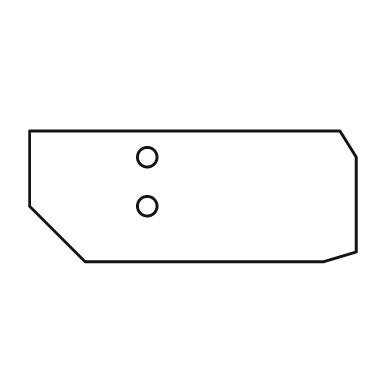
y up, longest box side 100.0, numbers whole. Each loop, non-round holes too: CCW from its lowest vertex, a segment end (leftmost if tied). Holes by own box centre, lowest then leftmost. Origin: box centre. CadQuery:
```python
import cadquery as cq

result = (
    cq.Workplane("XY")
    .moveTo(-33.0, -20.0)
    .lineTo(40.0, -20.0)
    .lineTo(50.0, -17.0)
    .lineTo(50.0, 12.0)
    .lineTo(45.0, 20.0)
    .lineTo(-50.0, 20.0)
    .lineTo(-50.0, -3.0)
    .close()
    .moveTo(-14.0, -3.0)
    .circle(3.0)
    .moveTo(-14.0, 12.0)
    .circle(3.0)
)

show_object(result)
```